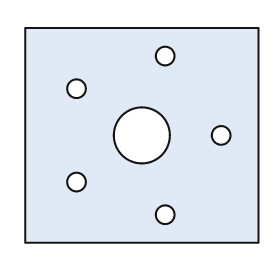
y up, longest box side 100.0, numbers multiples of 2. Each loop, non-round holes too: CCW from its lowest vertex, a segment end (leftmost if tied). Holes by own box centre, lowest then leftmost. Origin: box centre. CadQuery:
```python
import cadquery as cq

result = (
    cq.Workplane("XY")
    .moveTo(-50.0, -46.0)
    .lineTo(50.0, -46.0)
    .lineTo(50.0, 46.0)
    .lineTo(-50.0, 46.0)
    .close()
    .moveTo(10.0, -34.0)
    .circle(4.0)
    .moveTo(-28.0, -20.0)
    .circle(4.0)
    .moveTo(0.0, 0.0)
    .circle(12.0)
    .moveTo(34.0, 0.0)
    .circle(4.0)
    .moveTo(-28.0, 20.0)
    .circle(4.0)
    .moveTo(10.0, 34.0)
    .circle(4.0)
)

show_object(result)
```